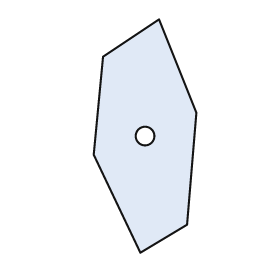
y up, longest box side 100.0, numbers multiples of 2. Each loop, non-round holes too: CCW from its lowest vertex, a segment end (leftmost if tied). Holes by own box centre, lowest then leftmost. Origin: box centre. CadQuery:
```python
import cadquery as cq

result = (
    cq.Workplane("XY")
    .moveTo(-2.0, -50.0)
    .lineTo(18.0, -38.0)
    .lineTo(22.0, 10.0)
    .lineTo(6.0, 50.0)
    .lineTo(-18.0, 34.0)
    .lineTo(-22.0, -8.0)
    .close()
    .moveTo(0.0, 0.0)
    .circle(4.0)
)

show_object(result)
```